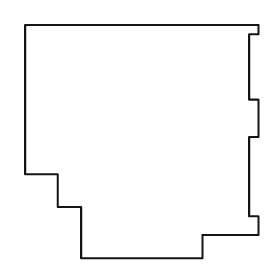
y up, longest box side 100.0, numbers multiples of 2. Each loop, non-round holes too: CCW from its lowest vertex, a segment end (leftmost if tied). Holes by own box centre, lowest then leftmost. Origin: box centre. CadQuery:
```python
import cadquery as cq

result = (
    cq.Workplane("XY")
    .moveTo(-26.0, -50.0)
    .lineTo(26.0, -50.0)
    .lineTo(26.0, -40.0)
    .lineTo(50.0, -40.0)
    .lineTo(50.0, -32.0)
    .lineTo(46.0, -32.0)
    .lineTo(46.0, 2.0)
    .lineTo(50.0, 2.0)
    .lineTo(50.0, 18.0)
    .lineTo(46.0, 18.0)
    .lineTo(46.0, 46.0)
    .lineTo(50.0, 46.0)
    .lineTo(50.0, 50.0)
    .lineTo(-50.0, 50.0)
    .lineTo(-50.0, -14.0)
    .lineTo(-36.0, -14.0)
    .lineTo(-36.0, -28.0)
    .lineTo(-26.0, -28.0)
    .close()
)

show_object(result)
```